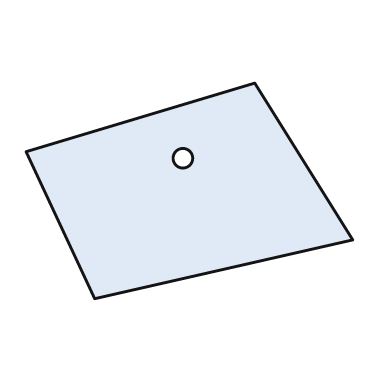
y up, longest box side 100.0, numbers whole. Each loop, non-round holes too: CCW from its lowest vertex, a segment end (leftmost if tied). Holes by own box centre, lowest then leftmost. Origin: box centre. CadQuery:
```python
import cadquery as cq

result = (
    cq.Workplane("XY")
    .moveTo(-29.0, -33.0)
    .lineTo(50.0, -15.0)
    .lineTo(20.0, 33.0)
    .lineTo(-50.0, 12.0)
    .close()
    .moveTo(-2.0, 10.0)
    .circle(3.0)
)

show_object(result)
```